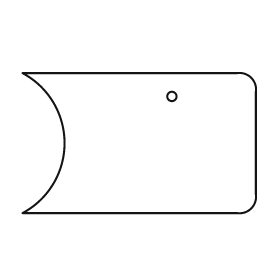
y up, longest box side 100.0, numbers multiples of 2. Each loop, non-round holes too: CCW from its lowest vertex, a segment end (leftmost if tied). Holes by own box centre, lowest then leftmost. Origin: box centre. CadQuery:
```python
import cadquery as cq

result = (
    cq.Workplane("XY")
    .moveTo(-50.0, -30.0)
    .lineTo(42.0, -30.0)
    .threePointArc((48.0, -28.0), (50.0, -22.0))
    .lineTo(50.0, 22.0)
    .threePointArc((48.0, 28.0), (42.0, 30.0))
    .lineTo(-50.0, 30.0)
    .threePointArc((-32.0, 0.0), (-50.0, -30.0))
    .close()
    .moveTo(14.0, 20.0)
    .circle(2.0)
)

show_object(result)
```